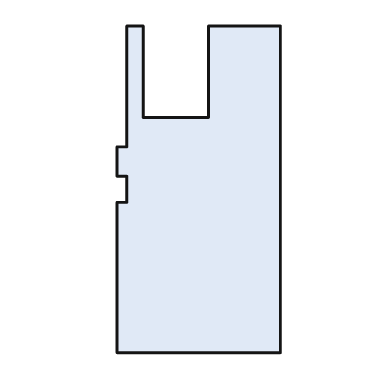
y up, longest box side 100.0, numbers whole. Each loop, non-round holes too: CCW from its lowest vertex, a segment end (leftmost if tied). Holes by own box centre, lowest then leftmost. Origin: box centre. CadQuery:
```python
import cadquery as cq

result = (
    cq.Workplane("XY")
    .moveTo(-25.0, -50.0)
    .lineTo(25.0, -50.0)
    .lineTo(25.0, 50.0)
    .lineTo(3.0, 50.0)
    .lineTo(3.0, 22.0)
    .lineTo(-17.0, 22.0)
    .lineTo(-17.0, 50.0)
    .lineTo(-22.0, 50.0)
    .lineTo(-22.0, 13.0)
    .lineTo(-25.0, 13.0)
    .lineTo(-25.0, 4.0)
    .lineTo(-22.0, 4.0)
    .lineTo(-22.0, -4.0)
    .lineTo(-25.0, -4.0)
    .close()
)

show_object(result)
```